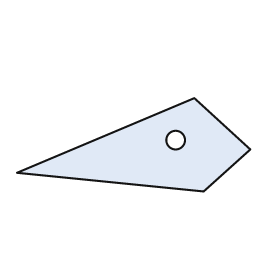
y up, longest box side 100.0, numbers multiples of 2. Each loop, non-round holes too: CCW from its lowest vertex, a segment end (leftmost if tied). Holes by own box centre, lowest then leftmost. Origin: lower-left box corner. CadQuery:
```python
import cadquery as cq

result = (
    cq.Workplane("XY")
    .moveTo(80.0, 0.0)
    .lineTo(100.0, 18.0)
    .lineTo(76.0, 40.0)
    .lineTo(0.0, 8.0)
    .close()
    .moveTo(68.0, 22.0)
    .circle(4.0)
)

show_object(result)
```